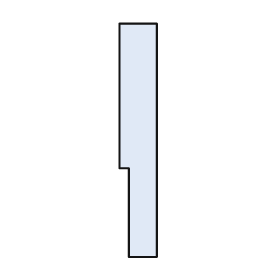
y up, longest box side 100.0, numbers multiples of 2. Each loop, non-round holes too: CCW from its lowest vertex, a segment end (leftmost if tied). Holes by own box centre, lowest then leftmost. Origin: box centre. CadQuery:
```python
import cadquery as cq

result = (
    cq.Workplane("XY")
    .moveTo(-4.0, -50.0)
    .lineTo(8.0, -50.0)
    .lineTo(8.0, 50.0)
    .lineTo(-8.0, 50.0)
    .lineTo(-8.0, -12.0)
    .lineTo(-4.0, -12.0)
    .close()
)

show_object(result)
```